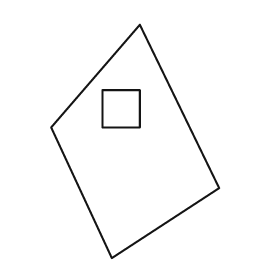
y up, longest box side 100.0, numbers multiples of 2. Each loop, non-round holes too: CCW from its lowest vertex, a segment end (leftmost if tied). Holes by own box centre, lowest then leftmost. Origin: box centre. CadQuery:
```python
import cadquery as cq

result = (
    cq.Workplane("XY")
    .moveTo(-10.0, -50.0)
    .lineTo(36.0, -20.0)
    .lineTo(2.0, 50.0)
    .lineTo(-36.0, 6.0)
    .close()
    .moveTo(-14.0, 6.0)
    .lineTo(2.0, 6.0)
    .lineTo(2.0, 22.0)
    .lineTo(-14.0, 22.0)
    .close()
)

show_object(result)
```